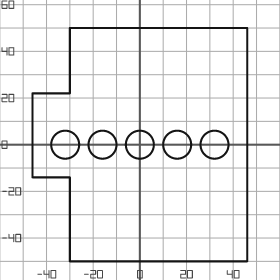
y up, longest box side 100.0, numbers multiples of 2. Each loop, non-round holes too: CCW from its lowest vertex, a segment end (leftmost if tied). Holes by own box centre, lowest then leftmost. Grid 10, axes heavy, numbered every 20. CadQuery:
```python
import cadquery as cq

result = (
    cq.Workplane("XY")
    .moveTo(-30.0, -50.0)
    .lineTo(46.0, -50.0)
    .lineTo(46.0, 50.0)
    .lineTo(-30.0, 50.0)
    .lineTo(-30.0, 22.0)
    .lineTo(-46.0, 22.0)
    .lineTo(-46.0, -14.0)
    .lineTo(-30.0, -14.0)
    .close()
    .moveTo(-32.0, 0.0)
    .circle(6.0)
    .moveTo(-16.0, 0.0)
    .circle(6.0)
    .moveTo(0.0, 0.0)
    .circle(6.0)
    .moveTo(16.0, 0.0)
    .circle(6.0)
    .moveTo(32.0, 0.0)
    .circle(6.0)
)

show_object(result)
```